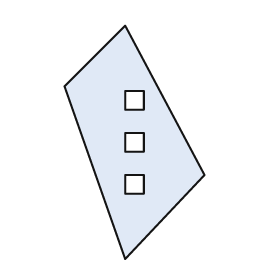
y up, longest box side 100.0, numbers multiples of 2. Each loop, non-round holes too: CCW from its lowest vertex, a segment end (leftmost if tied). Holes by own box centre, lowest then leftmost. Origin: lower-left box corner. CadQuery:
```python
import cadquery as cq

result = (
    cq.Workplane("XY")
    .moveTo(26.0, 0.0)
    .lineTo(60.0, 36.0)
    .lineTo(26.0, 100.0)
    .lineTo(0.0, 74.0)
    .close()
    .moveTo(26.0, 28.0)
    .lineTo(34.0, 28.0)
    .lineTo(34.0, 36.0)
    .lineTo(26.0, 36.0)
    .close()
    .moveTo(26.0, 46.0)
    .lineTo(34.0, 46.0)
    .lineTo(34.0, 54.0)
    .lineTo(26.0, 54.0)
    .close()
    .moveTo(26.0, 64.0)
    .lineTo(34.0, 64.0)
    .lineTo(34.0, 72.0)
    .lineTo(26.0, 72.0)
    .close()
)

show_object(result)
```